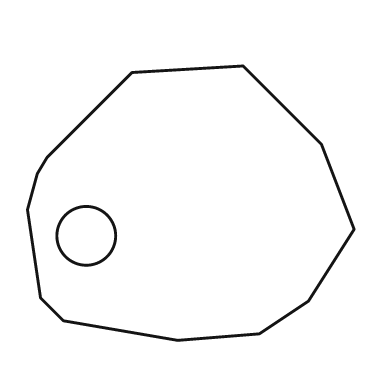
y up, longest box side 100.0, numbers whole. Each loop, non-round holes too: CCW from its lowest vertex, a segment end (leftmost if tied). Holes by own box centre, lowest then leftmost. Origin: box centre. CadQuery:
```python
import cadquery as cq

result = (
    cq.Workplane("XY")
    .moveTo(-4.0, -42.0)
    .lineTo(21.0, -40.0)
    .lineTo(36.0, -30.0)
    .lineTo(50.0, -8.0)
    .lineTo(40.0, 18.0)
    .lineTo(16.0, 42.0)
    .lineTo(-18.0, 40.0)
    .lineTo(-44.0, 14.0)
    .lineTo(-47.0, 9.0)
    .lineTo(-50.0, -2.0)
    .lineTo(-46.0, -29.0)
    .lineTo(-39.0, -36.0)
    .close()
    .moveTo(-32.0, -10.0)
    .circle(9.0)
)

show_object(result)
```